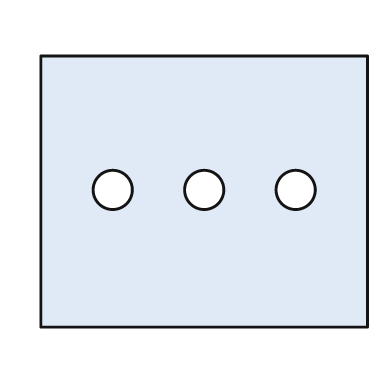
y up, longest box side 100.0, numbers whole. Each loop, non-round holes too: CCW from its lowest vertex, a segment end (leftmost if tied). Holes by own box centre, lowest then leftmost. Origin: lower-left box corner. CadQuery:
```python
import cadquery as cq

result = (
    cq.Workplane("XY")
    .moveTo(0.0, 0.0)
    .lineTo(100.0, 0.0)
    .lineTo(100.0, 83.0)
    .lineTo(0.0, 83.0)
    .close()
    .moveTo(22.0, 42.0)
    .circle(6.0)
    .moveTo(50.0, 42.0)
    .circle(6.0)
    .moveTo(78.0, 42.0)
    .circle(6.0)
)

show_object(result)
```